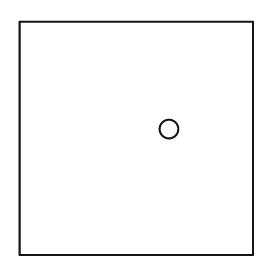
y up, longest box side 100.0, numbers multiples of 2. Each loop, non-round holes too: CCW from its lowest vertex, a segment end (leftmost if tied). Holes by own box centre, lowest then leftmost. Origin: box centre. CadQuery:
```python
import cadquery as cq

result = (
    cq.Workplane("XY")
    .moveTo(-50.0, -50.0)
    .lineTo(50.0, -50.0)
    .lineTo(50.0, 50.0)
    .lineTo(-50.0, 50.0)
    .close()
    .moveTo(14.0, 4.0)
    .circle(4.0)
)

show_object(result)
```